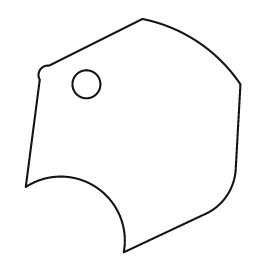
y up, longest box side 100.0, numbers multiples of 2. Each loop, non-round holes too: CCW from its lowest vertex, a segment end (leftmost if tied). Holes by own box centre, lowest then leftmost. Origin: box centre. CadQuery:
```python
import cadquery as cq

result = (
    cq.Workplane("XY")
    .moveTo(-4.0, -50.0)
    .lineTo(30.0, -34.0)
    .threePointArc((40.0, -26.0), (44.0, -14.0))
    .lineTo(46.0, 22.0)
    .threePointArc((28.0, 40.0), (4.0, 50.0))
    .lineTo(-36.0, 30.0)
    .threePointArc((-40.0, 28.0), (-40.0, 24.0))
    .lineTo(-46.0, -22.0)
    .threePointArc((-16.0, -22.0), (-4.0, -50.0))
    .close()
    .moveTo(-20.0, 22.0)
    .circle(6.0)
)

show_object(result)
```